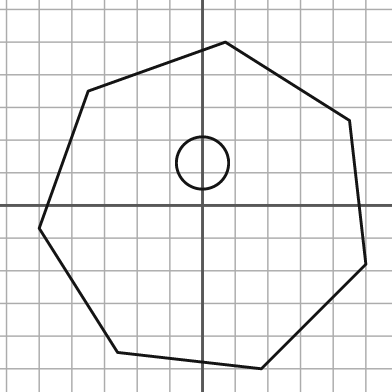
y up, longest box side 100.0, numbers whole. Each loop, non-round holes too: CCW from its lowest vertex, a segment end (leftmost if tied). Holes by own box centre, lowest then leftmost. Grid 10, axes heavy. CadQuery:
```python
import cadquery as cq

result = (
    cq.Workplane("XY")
    .moveTo(18.0, -50.0)
    .lineTo(50.0, -18.0)
    .lineTo(45.0, 26.0)
    .lineTo(7.0, 50.0)
    .lineTo(-35.0, 35.0)
    .lineTo(-50.0, -7.0)
    .lineTo(-26.0, -45.0)
    .close()
    .moveTo(0.0, 13.0)
    .circle(8.0)
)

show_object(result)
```